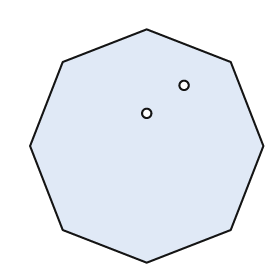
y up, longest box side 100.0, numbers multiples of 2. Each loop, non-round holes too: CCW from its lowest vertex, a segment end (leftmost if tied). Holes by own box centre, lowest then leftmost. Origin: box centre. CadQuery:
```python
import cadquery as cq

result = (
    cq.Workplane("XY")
    .moveTo(0.0, -50.0)
    .lineTo(36.0, -36.0)
    .lineTo(50.0, 0.0)
    .lineTo(36.0, 36.0)
    .lineTo(0.0, 50.0)
    .lineTo(-36.0, 36.0)
    .lineTo(-50.0, 0.0)
    .lineTo(-36.0, -36.0)
    .close()
    .moveTo(0.0, 14.0)
    .circle(2.0)
    .moveTo(16.0, 26.0)
    .circle(2.0)
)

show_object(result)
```